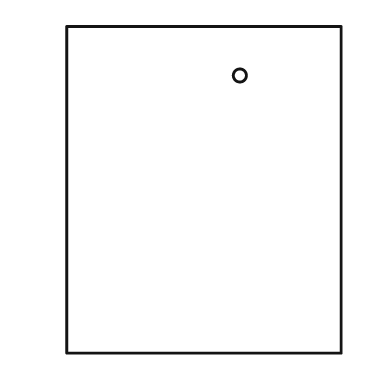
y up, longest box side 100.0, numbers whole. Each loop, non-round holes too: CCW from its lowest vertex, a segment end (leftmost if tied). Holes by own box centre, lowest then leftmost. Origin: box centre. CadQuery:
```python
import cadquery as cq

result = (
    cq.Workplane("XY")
    .moveTo(-42.0, -50.0)
    .lineTo(42.0, -50.0)
    .lineTo(42.0, 50.0)
    .lineTo(-42.0, 50.0)
    .close()
    .moveTo(11.0, 35.0)
    .circle(2.0)
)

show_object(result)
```